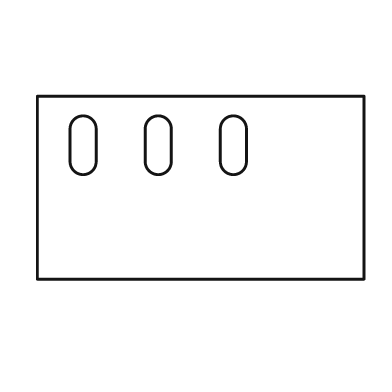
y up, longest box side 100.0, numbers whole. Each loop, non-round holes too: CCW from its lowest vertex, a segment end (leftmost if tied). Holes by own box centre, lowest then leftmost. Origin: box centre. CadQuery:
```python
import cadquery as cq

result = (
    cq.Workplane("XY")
    .moveTo(-50.0, -28.0)
    .lineTo(50.0, -28.0)
    .lineTo(50.0, 28.0)
    .lineTo(-50.0, 28.0)
    .close()
    .moveTo(-40.0, 8.0)
    .threePointArc((-36.0, 4.0), (-32.0, 8.0))
    .lineTo(-32.0, 18.0)
    .threePointArc((-36.0, 22.0), (-40.0, 18.0))
    .close()
    .moveTo(-17.0, 8.0)
    .threePointArc((-13.0, 4.0), (-9.0, 8.0))
    .lineTo(-9.0, 18.0)
    .threePointArc((-13.0, 22.0), (-17.0, 18.0))
    .close()
    .moveTo(6.0, 8.0)
    .threePointArc((10.0, 4.0), (14.0, 8.0))
    .lineTo(14.0, 18.0)
    .threePointArc((10.0, 22.0), (6.0, 18.0))
    .close()
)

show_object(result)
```